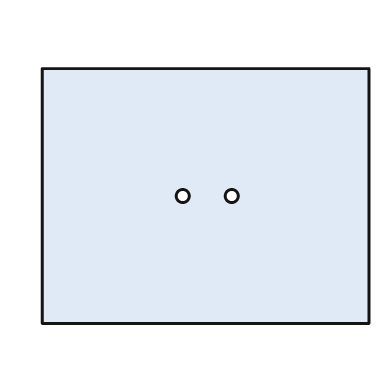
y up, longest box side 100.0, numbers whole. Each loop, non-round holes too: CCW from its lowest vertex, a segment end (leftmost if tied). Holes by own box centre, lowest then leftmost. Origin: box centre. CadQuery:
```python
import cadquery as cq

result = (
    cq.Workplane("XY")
    .moveTo(-50.0, -39.0)
    .lineTo(50.0, -39.0)
    .lineTo(50.0, 39.0)
    .lineTo(-50.0, 39.0)
    .close()
    .moveTo(-7.0, 0.0)
    .circle(2.0)
    .moveTo(8.0, 0.0)
    .circle(2.0)
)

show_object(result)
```